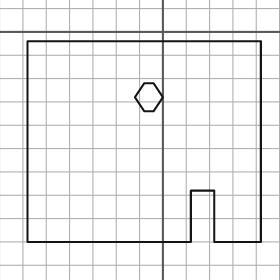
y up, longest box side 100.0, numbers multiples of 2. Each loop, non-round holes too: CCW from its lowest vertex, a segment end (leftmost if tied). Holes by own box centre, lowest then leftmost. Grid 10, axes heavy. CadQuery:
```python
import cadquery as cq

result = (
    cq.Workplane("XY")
    .moveTo(-58.0, -90.0)
    .lineTo(12.0, -90.0)
    .lineTo(12.0, -68.0)
    .lineTo(22.0, -68.0)
    .lineTo(22.0, -90.0)
    .lineTo(42.0, -90.0)
    .lineTo(42.0, -4.0)
    .lineTo(-58.0, -4.0)
    .close()
    .moveTo(-8.0, -34.0)
    .lineTo(-4.0, -34.0)
    .lineTo(0.0, -28.0)
    .lineTo(-4.0, -22.0)
    .lineTo(-8.0, -22.0)
    .lineTo(-12.0, -28.0)
    .close()
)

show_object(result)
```